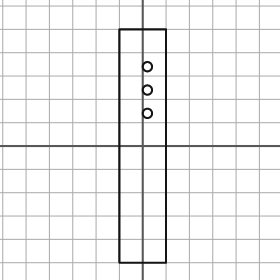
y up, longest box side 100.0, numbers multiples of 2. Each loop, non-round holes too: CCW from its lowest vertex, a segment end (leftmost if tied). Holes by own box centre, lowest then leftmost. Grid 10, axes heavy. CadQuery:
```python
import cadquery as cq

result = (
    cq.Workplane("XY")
    .moveTo(-10.0, -50.0)
    .lineTo(10.0, -50.0)
    .lineTo(10.0, 50.0)
    .lineTo(-10.0, 50.0)
    .close()
    .moveTo(2.0, 14.0)
    .circle(2.0)
    .moveTo(2.0, 24.0)
    .circle(2.0)
    .moveTo(2.0, 34.0)
    .circle(2.0)
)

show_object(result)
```